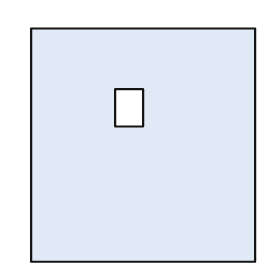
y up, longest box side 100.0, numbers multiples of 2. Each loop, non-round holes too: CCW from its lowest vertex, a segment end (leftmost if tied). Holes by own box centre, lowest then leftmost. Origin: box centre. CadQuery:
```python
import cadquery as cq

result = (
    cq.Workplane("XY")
    .moveTo(-48.0, -50.0)
    .lineTo(48.0, -50.0)
    .lineTo(48.0, 50.0)
    .lineTo(-48.0, 50.0)
    .close()
    .moveTo(-12.0, 8.0)
    .lineTo(0.0, 8.0)
    .lineTo(0.0, 24.0)
    .lineTo(-12.0, 24.0)
    .close()
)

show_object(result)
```